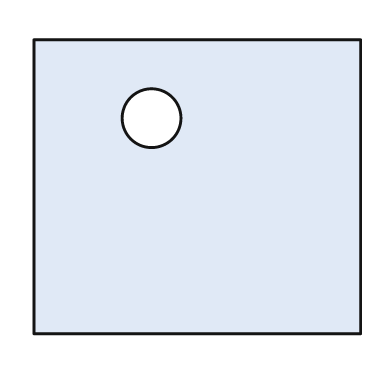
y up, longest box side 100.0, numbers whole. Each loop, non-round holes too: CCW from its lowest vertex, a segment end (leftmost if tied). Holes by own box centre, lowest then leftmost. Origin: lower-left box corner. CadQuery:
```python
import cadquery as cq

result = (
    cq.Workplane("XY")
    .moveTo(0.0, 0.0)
    .lineTo(100.0, 0.0)
    .lineTo(100.0, 90.0)
    .lineTo(0.0, 90.0)
    .close()
    .moveTo(36.0, 66.0)
    .circle(9.0)
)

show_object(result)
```